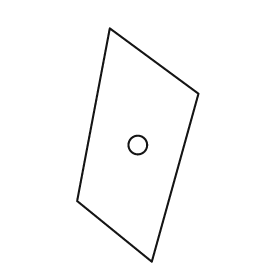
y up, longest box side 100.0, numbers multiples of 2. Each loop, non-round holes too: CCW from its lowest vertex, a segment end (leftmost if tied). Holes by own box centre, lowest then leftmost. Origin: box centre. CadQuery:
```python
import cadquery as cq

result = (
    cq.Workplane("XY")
    .moveTo(6.0, -50.0)
    .lineTo(26.0, 22.0)
    .lineTo(-12.0, 50.0)
    .lineTo(-26.0, -24.0)
    .close()
    .moveTo(0.0, 0.0)
    .circle(4.0)
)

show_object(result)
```